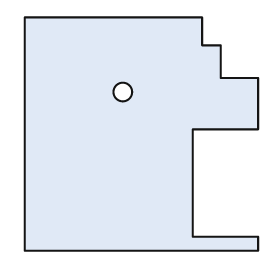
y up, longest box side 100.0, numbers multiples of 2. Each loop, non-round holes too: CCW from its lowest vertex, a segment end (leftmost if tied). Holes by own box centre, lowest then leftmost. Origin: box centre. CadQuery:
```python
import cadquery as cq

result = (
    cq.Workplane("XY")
    .moveTo(-50.0, -50.0)
    .lineTo(50.0, -50.0)
    .lineTo(50.0, -44.0)
    .lineTo(22.0, -44.0)
    .lineTo(22.0, 2.0)
    .lineTo(50.0, 2.0)
    .lineTo(50.0, 24.0)
    .lineTo(34.0, 24.0)
    .lineTo(34.0, 38.0)
    .lineTo(26.0, 38.0)
    .lineTo(26.0, 50.0)
    .lineTo(-50.0, 50.0)
    .close()
    .moveTo(-8.0, 18.0)
    .circle(4.0)
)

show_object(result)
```